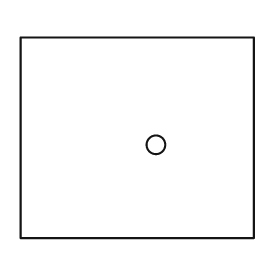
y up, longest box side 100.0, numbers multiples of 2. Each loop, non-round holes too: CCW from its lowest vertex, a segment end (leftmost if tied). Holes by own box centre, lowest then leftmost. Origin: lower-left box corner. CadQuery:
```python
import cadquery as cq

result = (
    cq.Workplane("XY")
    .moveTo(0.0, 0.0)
    .lineTo(100.0, 0.0)
    .lineTo(100.0, 86.0)
    .lineTo(0.0, 86.0)
    .close()
    .moveTo(58.0, 40.0)
    .circle(4.0)
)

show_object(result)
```